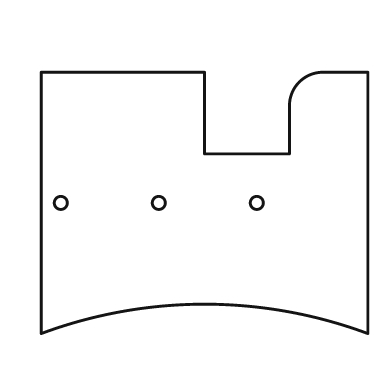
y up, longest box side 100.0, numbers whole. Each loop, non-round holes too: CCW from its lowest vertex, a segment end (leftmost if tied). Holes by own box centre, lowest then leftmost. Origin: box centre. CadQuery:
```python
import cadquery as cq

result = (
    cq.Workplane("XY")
    .moveTo(-50.0, -40.0)
    .threePointArc((0.0, -31.0), (50.0, -40.0))
    .lineTo(50.0, 40.0)
    .lineTo(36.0, 40.0)
    .threePointArc((29.0, 37.0), (26.0, 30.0))
    .lineTo(26.0, 15.0)
    .lineTo(0.0, 15.0)
    .lineTo(0.0, 40.0)
    .lineTo(-50.0, 40.0)
    .close()
    .moveTo(-44.0, 0.0)
    .circle(2.0)
    .moveTo(-14.0, 0.0)
    .circle(2.0)
    .moveTo(16.0, 0.0)
    .circle(2.0)
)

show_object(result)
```